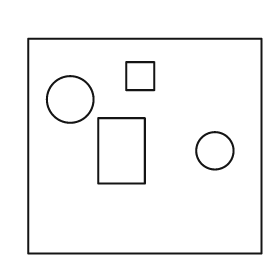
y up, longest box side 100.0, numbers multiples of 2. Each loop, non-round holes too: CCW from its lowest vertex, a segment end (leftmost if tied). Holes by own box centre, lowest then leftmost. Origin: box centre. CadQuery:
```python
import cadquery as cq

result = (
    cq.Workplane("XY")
    .moveTo(-50.0, -46.0)
    .lineTo(50.0, -46.0)
    .lineTo(50.0, 46.0)
    .lineTo(-50.0, 46.0)
    .close()
    .moveTo(-20.0, -16.0)
    .lineTo(0.0, -16.0)
    .lineTo(0.0, 12.0)
    .lineTo(-20.0, 12.0)
    .close()
    .moveTo(30.0, -2.0)
    .circle(8.0)
    .moveTo(-32.0, 20.0)
    .circle(10.0)
    .moveTo(-8.0, 24.0)
    .lineTo(4.0, 24.0)
    .lineTo(4.0, 36.0)
    .lineTo(-8.0, 36.0)
    .close()
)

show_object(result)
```